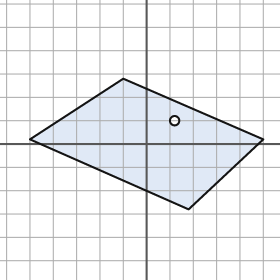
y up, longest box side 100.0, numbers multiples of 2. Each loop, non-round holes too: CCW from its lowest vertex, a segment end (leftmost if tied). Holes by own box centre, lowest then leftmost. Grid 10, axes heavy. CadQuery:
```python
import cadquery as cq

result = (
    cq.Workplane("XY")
    .moveTo(18.0, -28.0)
    .lineTo(50.0, 2.0)
    .lineTo(-10.0, 28.0)
    .lineTo(-50.0, 2.0)
    .close()
    .moveTo(12.0, 10.0)
    .circle(2.0)
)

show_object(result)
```